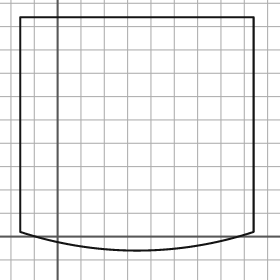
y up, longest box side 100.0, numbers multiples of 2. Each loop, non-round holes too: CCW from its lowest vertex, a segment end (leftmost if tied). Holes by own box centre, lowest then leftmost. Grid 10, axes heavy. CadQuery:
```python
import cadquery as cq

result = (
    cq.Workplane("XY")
    .moveTo(-16.0, 2.0)
    .threePointArc((34.0, -6.0), (84.0, 2.0))
    .lineTo(84.0, 94.0)
    .lineTo(-16.0, 94.0)
    .close()
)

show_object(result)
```